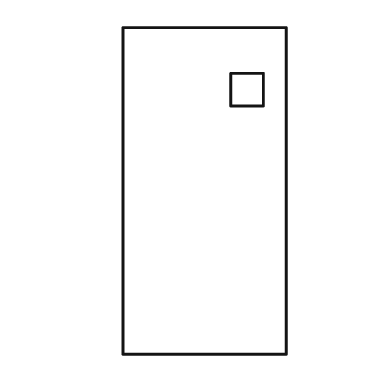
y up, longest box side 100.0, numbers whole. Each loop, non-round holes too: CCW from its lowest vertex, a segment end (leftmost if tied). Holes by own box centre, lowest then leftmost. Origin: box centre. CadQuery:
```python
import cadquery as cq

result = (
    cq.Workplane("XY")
    .moveTo(-25.0, -50.0)
    .lineTo(25.0, -50.0)
    .lineTo(25.0, 50.0)
    .lineTo(-25.0, 50.0)
    .close()
    .moveTo(8.0, 26.0)
    .lineTo(18.0, 26.0)
    .lineTo(18.0, 36.0)
    .lineTo(8.0, 36.0)
    .close()
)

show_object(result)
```